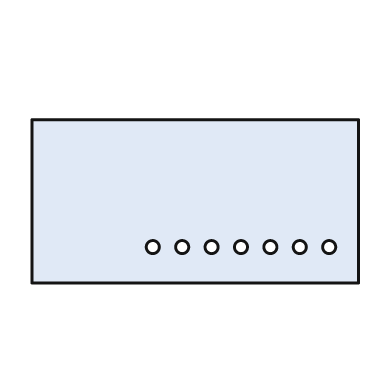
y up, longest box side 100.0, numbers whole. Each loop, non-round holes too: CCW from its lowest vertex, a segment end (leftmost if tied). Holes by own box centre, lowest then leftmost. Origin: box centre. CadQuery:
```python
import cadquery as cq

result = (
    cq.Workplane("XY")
    .moveTo(-50.0, -25.0)
    .lineTo(50.0, -25.0)
    .lineTo(50.0, 25.0)
    .lineTo(-50.0, 25.0)
    .close()
    .moveTo(-13.0, -14.0)
    .circle(2.0)
    .moveTo(-4.0, -14.0)
    .circle(2.0)
    .moveTo(5.0, -14.0)
    .circle(2.0)
    .moveTo(14.0, -14.0)
    .circle(2.0)
    .moveTo(23.0, -14.0)
    .circle(2.0)
    .moveTo(32.0, -14.0)
    .circle(2.0)
    .moveTo(41.0, -14.0)
    .circle(2.0)
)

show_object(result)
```